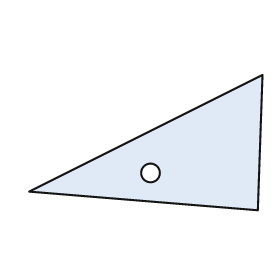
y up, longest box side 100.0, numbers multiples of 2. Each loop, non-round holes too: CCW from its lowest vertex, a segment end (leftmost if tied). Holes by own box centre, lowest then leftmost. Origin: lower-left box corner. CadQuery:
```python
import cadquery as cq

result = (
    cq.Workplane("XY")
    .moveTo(98.0, 0.0)
    .lineTo(100.0, 58.0)
    .lineTo(0.0, 8.0)
    .close()
    .moveTo(52.0, 16.0)
    .circle(4.0)
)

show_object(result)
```